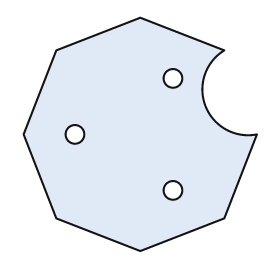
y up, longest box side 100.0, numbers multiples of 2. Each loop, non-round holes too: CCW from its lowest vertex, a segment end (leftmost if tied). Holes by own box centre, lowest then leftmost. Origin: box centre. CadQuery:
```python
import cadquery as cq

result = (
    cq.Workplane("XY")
    .moveTo(0.0, -50.0)
    .lineTo(36.0, -36.0)
    .lineTo(50.0, 0.0)
    .threePointArc((28.0, 12.0), (36.0, 36.0))
    .lineTo(0.0, 50.0)
    .lineTo(-36.0, 36.0)
    .lineTo(-50.0, 0.0)
    .lineTo(-36.0, -36.0)
    .close()
    .moveTo(14.0, -24.0)
    .circle(4.0)
    .moveTo(-28.0, 0.0)
    .circle(4.0)
    .moveTo(14.0, 24.0)
    .circle(4.0)
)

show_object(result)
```